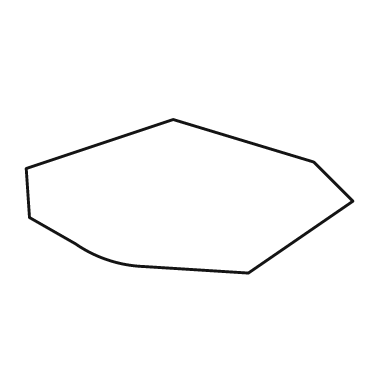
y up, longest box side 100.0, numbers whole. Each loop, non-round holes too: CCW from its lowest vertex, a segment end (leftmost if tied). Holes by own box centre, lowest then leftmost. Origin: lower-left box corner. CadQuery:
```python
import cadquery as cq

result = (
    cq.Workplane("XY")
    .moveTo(68.0, 0.0)
    .lineTo(100.0, 22.0)
    .lineTo(88.0, 34.0)
    .lineTo(45.0, 47.0)
    .lineTo(0.0, 32.0)
    .lineTo(1.0, 17.0)
    .lineTo(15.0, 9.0)
    .threePointArc((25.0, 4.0), (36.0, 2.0))
    .close()
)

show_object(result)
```